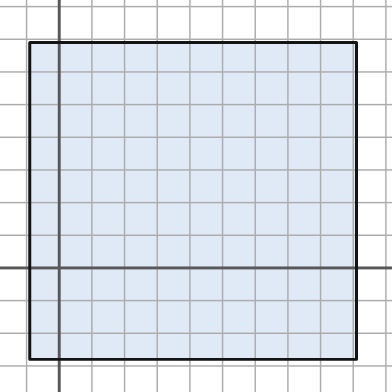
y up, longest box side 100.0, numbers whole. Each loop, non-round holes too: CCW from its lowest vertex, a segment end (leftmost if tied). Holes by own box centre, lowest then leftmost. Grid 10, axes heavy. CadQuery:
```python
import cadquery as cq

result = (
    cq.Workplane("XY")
    .moveTo(-9.0, -28.0)
    .lineTo(91.0, -28.0)
    .lineTo(91.0, 69.0)
    .lineTo(-9.0, 69.0)
    .close()
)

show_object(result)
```